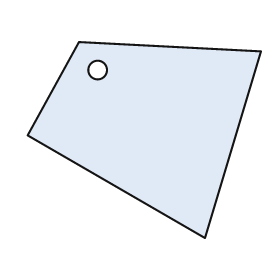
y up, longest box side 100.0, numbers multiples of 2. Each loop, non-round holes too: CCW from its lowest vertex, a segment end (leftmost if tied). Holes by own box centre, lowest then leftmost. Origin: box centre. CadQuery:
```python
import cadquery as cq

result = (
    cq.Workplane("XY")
    .moveTo(26.0, -42.0)
    .lineTo(50.0, 38.0)
    .lineTo(-28.0, 42.0)
    .lineTo(-50.0, 2.0)
    .close()
    .moveTo(-20.0, 30.0)
    .circle(4.0)
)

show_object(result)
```